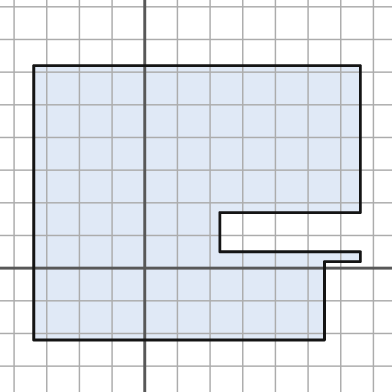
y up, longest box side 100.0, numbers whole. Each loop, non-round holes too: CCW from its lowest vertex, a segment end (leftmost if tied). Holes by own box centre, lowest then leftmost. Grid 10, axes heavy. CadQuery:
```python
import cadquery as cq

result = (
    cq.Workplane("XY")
    .moveTo(-34.0, -22.0)
    .lineTo(55.0, -22.0)
    .lineTo(55.0, 2.0)
    .lineTo(66.0, 2.0)
    .lineTo(66.0, 5.0)
    .lineTo(23.0, 5.0)
    .lineTo(23.0, 17.0)
    .lineTo(66.0, 17.0)
    .lineTo(66.0, 62.0)
    .lineTo(-34.0, 62.0)
    .close()
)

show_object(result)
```